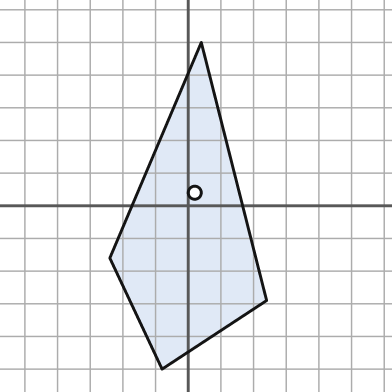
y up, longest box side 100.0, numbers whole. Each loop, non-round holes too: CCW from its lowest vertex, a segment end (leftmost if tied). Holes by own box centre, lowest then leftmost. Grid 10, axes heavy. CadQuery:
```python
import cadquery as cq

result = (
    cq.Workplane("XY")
    .moveTo(-8.0, -50.0)
    .lineTo(24.0, -29.0)
    .lineTo(4.0, 50.0)
    .lineTo(-24.0, -16.0)
    .close()
    .moveTo(2.0, 4.0)
    .circle(2.0)
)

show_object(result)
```